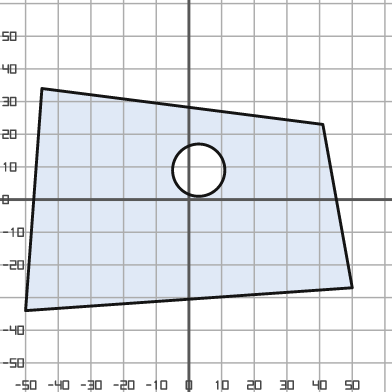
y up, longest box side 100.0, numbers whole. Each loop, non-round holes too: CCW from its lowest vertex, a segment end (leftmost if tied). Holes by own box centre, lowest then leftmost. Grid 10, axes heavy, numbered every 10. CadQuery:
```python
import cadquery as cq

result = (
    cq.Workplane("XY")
    .moveTo(-50.0, -34.0)
    .lineTo(50.0, -27.0)
    .lineTo(41.0, 23.0)
    .lineTo(-45.0, 34.0)
    .close()
    .moveTo(3.0, 9.0)
    .circle(8.0)
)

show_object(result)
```